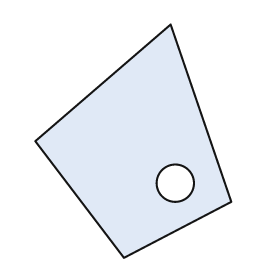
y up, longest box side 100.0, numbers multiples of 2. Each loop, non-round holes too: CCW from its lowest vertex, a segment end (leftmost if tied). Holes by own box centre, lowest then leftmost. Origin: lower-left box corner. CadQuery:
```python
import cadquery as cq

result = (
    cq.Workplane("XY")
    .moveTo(38.0, 0.0)
    .lineTo(84.0, 24.0)
    .lineTo(58.0, 100.0)
    .lineTo(0.0, 50.0)
    .close()
    .moveTo(60.0, 32.0)
    .circle(8.0)
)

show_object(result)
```